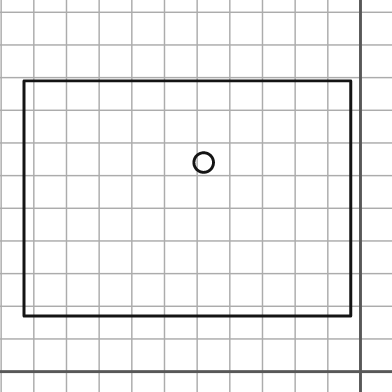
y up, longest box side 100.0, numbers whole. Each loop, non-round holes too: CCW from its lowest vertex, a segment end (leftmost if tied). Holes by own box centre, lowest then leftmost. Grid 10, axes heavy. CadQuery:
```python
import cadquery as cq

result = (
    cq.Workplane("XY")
    .moveTo(-103.0, 17.0)
    .lineTo(-3.0, 17.0)
    .lineTo(-3.0, 89.0)
    .lineTo(-103.0, 89.0)
    .close()
    .moveTo(-48.0, 64.0)
    .circle(3.0)
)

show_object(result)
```